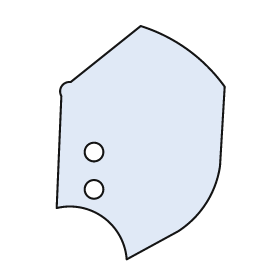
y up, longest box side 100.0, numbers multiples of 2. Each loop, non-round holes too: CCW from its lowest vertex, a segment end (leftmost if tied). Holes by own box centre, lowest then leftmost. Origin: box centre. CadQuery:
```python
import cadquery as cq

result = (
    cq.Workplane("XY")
    .moveTo(-6.0, -50.0)
    .lineTo(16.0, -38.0)
    .threePointArc((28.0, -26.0), (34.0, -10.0))
    .lineTo(36.0, 24.0)
    .threePointArc((20.0, 40.0), (0.0, 50.0))
    .lineTo(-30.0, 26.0)
    .threePointArc((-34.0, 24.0), (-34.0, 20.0))
    .lineTo(-36.0, -28.0)
    .threePointArc((-16.0, -32.0), (-6.0, -50.0))
    .close()
    .moveTo(-20.0, -20.0)
    .circle(4.0)
    .moveTo(-20.0, -4.0)
    .circle(4.0)
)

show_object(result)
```